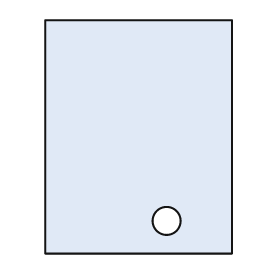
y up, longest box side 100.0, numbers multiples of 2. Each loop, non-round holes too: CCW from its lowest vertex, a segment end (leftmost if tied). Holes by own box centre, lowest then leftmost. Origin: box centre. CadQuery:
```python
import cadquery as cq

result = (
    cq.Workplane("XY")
    .moveTo(-40.0, -50.0)
    .lineTo(40.0, -50.0)
    .lineTo(40.0, 50.0)
    .lineTo(-40.0, 50.0)
    .close()
    .moveTo(12.0, -36.0)
    .circle(6.0)
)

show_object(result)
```